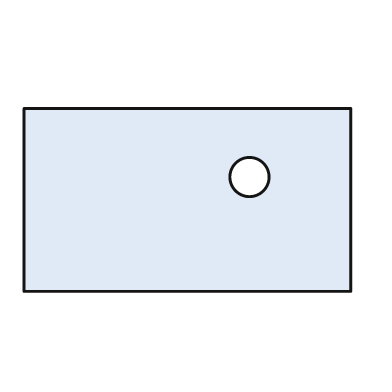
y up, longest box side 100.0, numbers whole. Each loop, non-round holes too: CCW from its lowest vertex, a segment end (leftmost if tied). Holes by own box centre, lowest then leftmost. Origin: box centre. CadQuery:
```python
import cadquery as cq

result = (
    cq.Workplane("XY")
    .moveTo(-50.0, -28.0)
    .lineTo(50.0, -28.0)
    .lineTo(50.0, 28.0)
    .lineTo(-50.0, 28.0)
    .close()
    .moveTo(19.0, 7.0)
    .circle(6.0)
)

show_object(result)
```